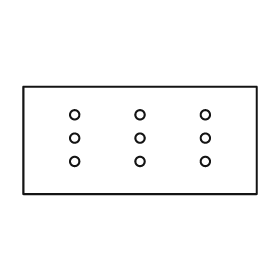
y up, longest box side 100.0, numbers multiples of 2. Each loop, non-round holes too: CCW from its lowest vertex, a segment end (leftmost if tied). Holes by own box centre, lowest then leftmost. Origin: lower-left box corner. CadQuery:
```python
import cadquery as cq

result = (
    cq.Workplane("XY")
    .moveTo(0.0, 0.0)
    .lineTo(100.0, 0.0)
    .lineTo(100.0, 46.0)
    .lineTo(0.0, 46.0)
    .close()
    .moveTo(22.0, 14.0)
    .circle(2.0)
    .moveTo(50.0, 14.0)
    .circle(2.0)
    .moveTo(78.0, 14.0)
    .circle(2.0)
    .moveTo(22.0, 24.0)
    .circle(2.0)
    .moveTo(50.0, 24.0)
    .circle(2.0)
    .moveTo(78.0, 24.0)
    .circle(2.0)
    .moveTo(22.0, 34.0)
    .circle(2.0)
    .moveTo(50.0, 34.0)
    .circle(2.0)
    .moveTo(78.0, 34.0)
    .circle(2.0)
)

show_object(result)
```